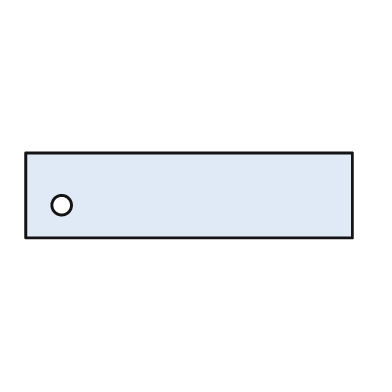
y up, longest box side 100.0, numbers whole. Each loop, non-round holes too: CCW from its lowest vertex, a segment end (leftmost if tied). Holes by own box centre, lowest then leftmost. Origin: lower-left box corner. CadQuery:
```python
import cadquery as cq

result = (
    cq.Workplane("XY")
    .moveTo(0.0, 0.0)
    .lineTo(100.0, 0.0)
    .lineTo(100.0, 26.0)
    .lineTo(0.0, 26.0)
    .close()
    .moveTo(11.0, 10.0)
    .circle(3.0)
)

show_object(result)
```